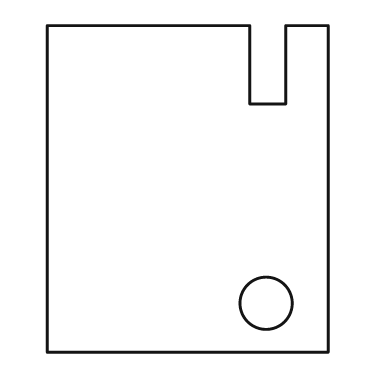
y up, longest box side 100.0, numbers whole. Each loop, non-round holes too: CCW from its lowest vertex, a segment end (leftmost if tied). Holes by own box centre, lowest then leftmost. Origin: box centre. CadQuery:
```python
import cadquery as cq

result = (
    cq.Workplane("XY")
    .moveTo(-43.0, -50.0)
    .lineTo(43.0, -50.0)
    .lineTo(43.0, 50.0)
    .lineTo(30.0, 50.0)
    .lineTo(30.0, 26.0)
    .lineTo(19.0, 26.0)
    .lineTo(19.0, 50.0)
    .lineTo(-43.0, 50.0)
    .close()
    .moveTo(24.0, -35.0)
    .circle(8.0)
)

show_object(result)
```